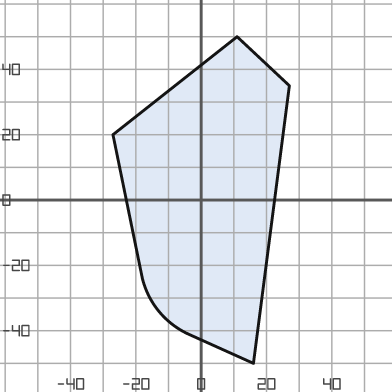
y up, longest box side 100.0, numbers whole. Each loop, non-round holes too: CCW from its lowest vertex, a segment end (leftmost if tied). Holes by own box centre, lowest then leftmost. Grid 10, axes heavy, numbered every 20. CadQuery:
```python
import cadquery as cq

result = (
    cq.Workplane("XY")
    .moveTo(16.0, -50.0)
    .lineTo(27.0, 35.0)
    .lineTo(11.0, 50.0)
    .lineTo(-27.0, 20.0)
    .lineTo(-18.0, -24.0)
    .threePointArc((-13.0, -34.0), (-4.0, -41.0))
    .close()
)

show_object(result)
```